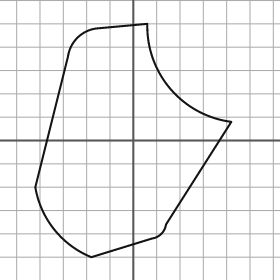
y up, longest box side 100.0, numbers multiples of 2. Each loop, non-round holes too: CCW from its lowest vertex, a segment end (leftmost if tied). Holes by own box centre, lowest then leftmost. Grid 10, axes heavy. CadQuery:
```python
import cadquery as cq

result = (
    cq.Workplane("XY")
    .moveTo(-18.0, -50.0)
    .lineTo(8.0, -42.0)
    .threePointArc((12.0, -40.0), (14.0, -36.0))
    .lineTo(42.0, 8.0)
    .threePointArc((16.0, 22.0), (6.0, 50.0))
    .lineTo(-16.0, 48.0)
    .threePointArc((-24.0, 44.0), (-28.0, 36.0))
    .lineTo(-42.0, -20.0)
    .threePointArc((-34.0, -38.0), (-18.0, -50.0))
    .close()
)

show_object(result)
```